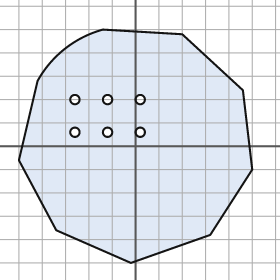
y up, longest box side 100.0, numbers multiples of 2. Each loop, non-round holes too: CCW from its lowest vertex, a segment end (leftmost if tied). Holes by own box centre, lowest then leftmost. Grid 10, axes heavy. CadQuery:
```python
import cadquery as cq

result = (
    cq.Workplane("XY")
    .moveTo(-2.0, -50.0)
    .lineTo(32.0, -38.0)
    .lineTo(50.0, -10.0)
    .lineTo(46.0, 24.0)
    .lineTo(20.0, 48.0)
    .lineTo(-14.0, 50.0)
    .threePointArc((-30.0, 42.0), (-42.0, 28.0))
    .lineTo(-50.0, -6.0)
    .lineTo(-34.0, -36.0)
    .close()
    .moveTo(-26.0, 6.0)
    .circle(2.0)
    .moveTo(-12.0, 6.0)
    .circle(2.0)
    .moveTo(2.0, 6.0)
    .circle(2.0)
    .moveTo(-26.0, 20.0)
    .circle(2.0)
    .moveTo(-12.0, 20.0)
    .circle(2.0)
    .moveTo(2.0, 20.0)
    .circle(2.0)
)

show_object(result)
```